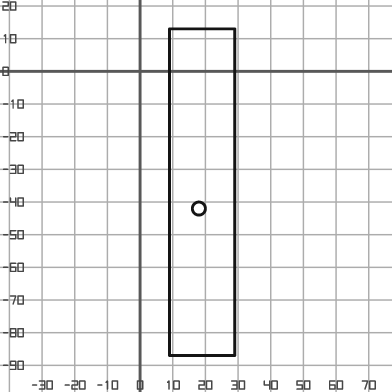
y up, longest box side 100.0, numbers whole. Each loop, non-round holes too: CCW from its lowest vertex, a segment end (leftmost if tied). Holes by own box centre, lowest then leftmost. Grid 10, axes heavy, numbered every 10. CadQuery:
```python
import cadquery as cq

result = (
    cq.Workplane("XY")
    .moveTo(9.0, -87.0)
    .lineTo(29.0, -87.0)
    .lineTo(29.0, 13.0)
    .lineTo(9.0, 13.0)
    .close()
    .moveTo(18.0, -42.0)
    .circle(2.0)
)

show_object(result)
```